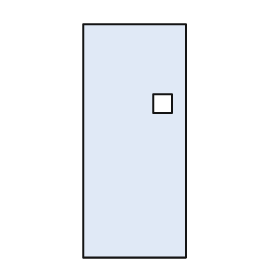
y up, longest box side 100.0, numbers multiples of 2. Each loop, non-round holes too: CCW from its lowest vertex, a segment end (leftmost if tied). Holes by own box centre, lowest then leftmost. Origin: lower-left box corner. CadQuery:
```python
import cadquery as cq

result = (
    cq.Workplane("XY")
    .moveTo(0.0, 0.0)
    .lineTo(44.0, 0.0)
    .lineTo(44.0, 100.0)
    .lineTo(0.0, 100.0)
    .close()
    .moveTo(30.0, 62.0)
    .lineTo(38.0, 62.0)
    .lineTo(38.0, 70.0)
    .lineTo(30.0, 70.0)
    .close()
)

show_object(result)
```